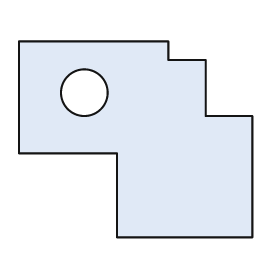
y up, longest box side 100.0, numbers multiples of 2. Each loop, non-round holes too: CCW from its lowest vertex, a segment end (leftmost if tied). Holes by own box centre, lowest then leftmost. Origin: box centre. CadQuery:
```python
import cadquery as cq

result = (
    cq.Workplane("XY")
    .moveTo(-8.0, -42.0)
    .lineTo(50.0, -42.0)
    .lineTo(50.0, 10.0)
    .lineTo(30.0, 10.0)
    .lineTo(30.0, 34.0)
    .lineTo(14.0, 34.0)
    .lineTo(14.0, 42.0)
    .lineTo(-50.0, 42.0)
    .lineTo(-50.0, -6.0)
    .lineTo(-8.0, -6.0)
    .close()
    .moveTo(-22.0, 20.0)
    .circle(10.0)
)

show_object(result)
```